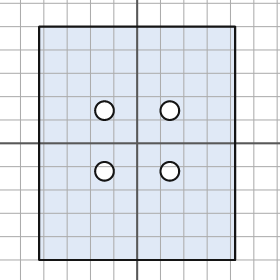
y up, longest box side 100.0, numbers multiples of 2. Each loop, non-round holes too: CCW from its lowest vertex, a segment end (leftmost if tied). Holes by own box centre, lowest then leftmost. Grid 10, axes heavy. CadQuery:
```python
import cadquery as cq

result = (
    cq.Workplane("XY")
    .moveTo(-42.0, -50.0)
    .lineTo(42.0, -50.0)
    .lineTo(42.0, 50.0)
    .lineTo(-42.0, 50.0)
    .close()
    .moveTo(-14.0, -12.0)
    .circle(4.0)
    .moveTo(14.0, -12.0)
    .circle(4.0)
    .moveTo(-14.0, 14.0)
    .circle(4.0)
    .moveTo(14.0, 14.0)
    .circle(4.0)
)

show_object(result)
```